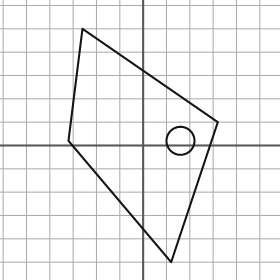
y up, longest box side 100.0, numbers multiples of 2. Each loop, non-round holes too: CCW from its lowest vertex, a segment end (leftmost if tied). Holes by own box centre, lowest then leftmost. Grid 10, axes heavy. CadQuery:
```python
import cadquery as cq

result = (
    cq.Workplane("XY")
    .moveTo(12.0, -50.0)
    .lineTo(32.0, 10.0)
    .lineTo(-26.0, 50.0)
    .lineTo(-32.0, 2.0)
    .close()
    .moveTo(16.0, 2.0)
    .circle(6.0)
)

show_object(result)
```